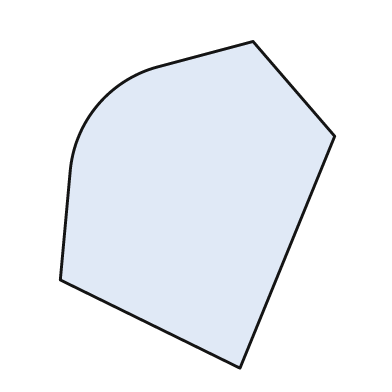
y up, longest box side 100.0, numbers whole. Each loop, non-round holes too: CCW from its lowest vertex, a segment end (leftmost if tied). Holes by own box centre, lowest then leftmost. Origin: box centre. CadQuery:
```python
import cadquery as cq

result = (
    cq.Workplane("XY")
    .moveTo(13.0, -50.0)
    .lineTo(42.0, 21.0)
    .lineTo(17.0, 50.0)
    .lineTo(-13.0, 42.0)
    .threePointArc((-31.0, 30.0), (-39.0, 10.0))
    .lineTo(-42.0, -23.0)
    .close()
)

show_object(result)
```